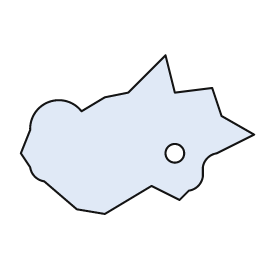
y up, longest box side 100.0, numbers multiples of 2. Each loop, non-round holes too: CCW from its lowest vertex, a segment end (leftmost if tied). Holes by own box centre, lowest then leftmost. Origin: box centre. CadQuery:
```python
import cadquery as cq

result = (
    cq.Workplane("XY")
    .moveTo(-14.0, -34.0)
    .lineTo(6.0, -22.0)
    .lineTo(18.0, -28.0)
    .lineTo(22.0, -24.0)
    .threePointArc((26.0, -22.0), (28.0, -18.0))
    .lineTo(28.0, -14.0)
    .threePointArc((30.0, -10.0), (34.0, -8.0))
    .lineTo(50.0, 0.0)
    .lineTo(36.0, 8.0)
    .lineTo(32.0, 20.0)
    .lineTo(16.0, 18.0)
    .lineTo(12.0, 34.0)
    .lineTo(-4.0, 18.0)
    .lineTo(-14.0, 16.0)
    .lineTo(-24.0, 10.0)
    .threePointArc((-38.0, 14.0), (-46.0, 2.0))
    .lineTo(-50.0, -8.0)
    .lineTo(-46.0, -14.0)
    .threePointArc((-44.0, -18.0), (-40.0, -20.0))
    .lineTo(-26.0, -32.0)
    .close()
    .moveTo(16.0, -8.0)
    .circle(4.0)
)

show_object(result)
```